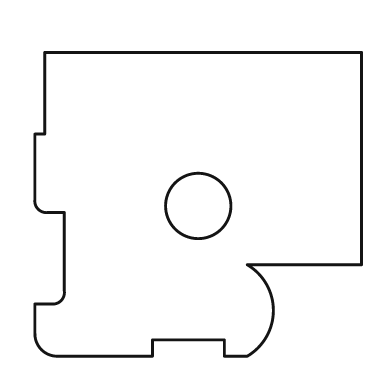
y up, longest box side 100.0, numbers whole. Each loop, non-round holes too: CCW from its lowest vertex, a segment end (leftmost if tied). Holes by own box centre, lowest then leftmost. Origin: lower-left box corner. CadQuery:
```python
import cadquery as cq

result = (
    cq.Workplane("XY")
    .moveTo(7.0, 0.0)
    .lineTo(36.0, 0.0)
    .lineTo(36.0, 5.0)
    .lineTo(58.0, 5.0)
    .lineTo(58.0, 0.0)
    .lineTo(65.0, 0.0)
    .threePointArc((73.0, 14.0), (65.0, 28.0))
    .lineTo(100.0, 28.0)
    .lineTo(100.0, 93.0)
    .lineTo(3.0, 93.0)
    .lineTo(3.0, 68.0)
    .lineTo(0.0, 68.0)
    .lineTo(0.0, 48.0)
    .threePointArc((1.0, 45.0), (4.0, 44.0))
    .lineTo(9.0, 44.0)
    .lineTo(9.0, 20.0)
    .threePointArc((8.0, 17.0), (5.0, 16.0))
    .lineTo(0.0, 16.0)
    .lineTo(0.0, 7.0)
    .threePointArc((2.0, 2.0), (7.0, 0.0))
    .close()
    .moveTo(50.0, 46.0)
    .circle(10.0)
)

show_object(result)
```